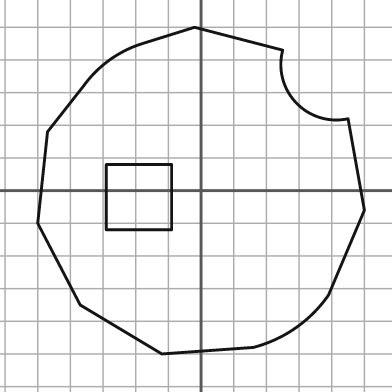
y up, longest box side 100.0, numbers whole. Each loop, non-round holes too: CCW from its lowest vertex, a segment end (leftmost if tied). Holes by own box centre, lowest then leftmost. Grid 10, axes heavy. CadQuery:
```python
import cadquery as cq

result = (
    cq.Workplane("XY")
    .moveTo(-12.0, -50.0)
    .lineTo(16.0, -48.0)
    .threePointArc((29.0, -42.0), (39.0, -32.0))
    .lineTo(50.0, -6.0)
    .lineTo(45.0, 22.0)
    .threePointArc((29.0, 27.0), (25.0, 43.0))
    .lineTo(-2.0, 50.0)
    .lineTo(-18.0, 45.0)
    .threePointArc((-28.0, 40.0), (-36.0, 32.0))
    .lineTo(-47.0, 18.0)
    .lineTo(-50.0, -10.0)
    .lineTo(-37.0, -35.0)
    .close()
    .moveTo(-29.0, -12.0)
    .lineTo(-9.0, -12.0)
    .lineTo(-9.0, 8.0)
    .lineTo(-29.0, 8.0)
    .close()
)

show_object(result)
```